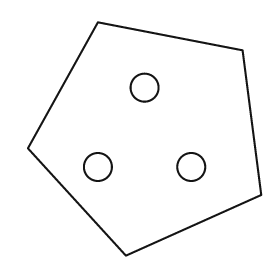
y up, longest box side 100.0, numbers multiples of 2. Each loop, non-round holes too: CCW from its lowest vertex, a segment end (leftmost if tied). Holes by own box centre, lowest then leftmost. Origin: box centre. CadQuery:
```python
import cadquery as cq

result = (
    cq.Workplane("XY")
    .moveTo(-8.0, -50.0)
    .lineTo(50.0, -24.0)
    .lineTo(42.0, 38.0)
    .lineTo(-20.0, 50.0)
    .lineTo(-50.0, -4.0)
    .close()
    .moveTo(-20.0, -12.0)
    .circle(6.0)
    .moveTo(20.0, -12.0)
    .circle(6.0)
    .moveTo(0.0, 22.0)
    .circle(6.0)
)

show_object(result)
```